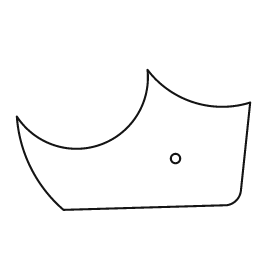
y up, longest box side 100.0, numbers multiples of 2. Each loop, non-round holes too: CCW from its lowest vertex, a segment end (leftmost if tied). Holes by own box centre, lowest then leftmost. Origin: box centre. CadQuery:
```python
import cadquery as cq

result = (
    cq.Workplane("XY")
    .moveTo(-30.0, -30.0)
    .lineTo(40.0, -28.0)
    .threePointArc((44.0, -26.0), (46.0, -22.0))
    .lineTo(50.0, 16.0)
    .threePointArc((26.0, 16.0), (6.0, 30.0))
    .threePointArc((-14.0, -2.0), (-50.0, 10.0))
    .threePointArc((-44.0, -12.0), (-30.0, -30.0))
    .close()
    .moveTo(18.0, -8.0)
    .circle(2.0)
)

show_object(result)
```